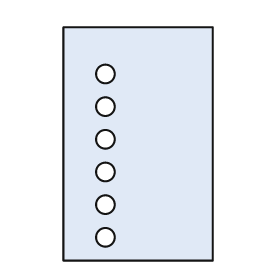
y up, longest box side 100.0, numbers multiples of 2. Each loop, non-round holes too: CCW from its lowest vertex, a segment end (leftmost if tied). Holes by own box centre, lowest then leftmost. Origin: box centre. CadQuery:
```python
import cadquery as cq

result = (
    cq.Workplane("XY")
    .moveTo(-32.0, -50.0)
    .lineTo(32.0, -50.0)
    .lineTo(32.0, 50.0)
    .lineTo(-32.0, 50.0)
    .close()
    .moveTo(-14.0, -40.0)
    .circle(4.0)
    .moveTo(-14.0, -26.0)
    .circle(4.0)
    .moveTo(-14.0, -12.0)
    .circle(4.0)
    .moveTo(-14.0, 2.0)
    .circle(4.0)
    .moveTo(-14.0, 16.0)
    .circle(4.0)
    .moveTo(-14.0, 30.0)
    .circle(4.0)
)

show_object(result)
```